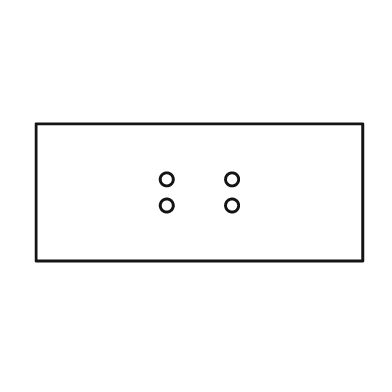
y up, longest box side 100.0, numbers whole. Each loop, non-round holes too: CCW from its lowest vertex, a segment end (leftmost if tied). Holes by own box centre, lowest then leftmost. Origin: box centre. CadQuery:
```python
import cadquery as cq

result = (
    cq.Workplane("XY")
    .moveTo(-50.0, -21.0)
    .lineTo(50.0, -21.0)
    .lineTo(50.0, 21.0)
    .lineTo(-50.0, 21.0)
    .close()
    .moveTo(-10.0, -4.0)
    .circle(2.0)
    .moveTo(10.0, -4.0)
    .circle(2.0)
    .moveTo(-10.0, 4.0)
    .circle(2.0)
    .moveTo(10.0, 4.0)
    .circle(2.0)
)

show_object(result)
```